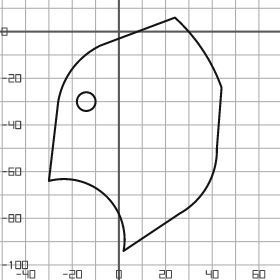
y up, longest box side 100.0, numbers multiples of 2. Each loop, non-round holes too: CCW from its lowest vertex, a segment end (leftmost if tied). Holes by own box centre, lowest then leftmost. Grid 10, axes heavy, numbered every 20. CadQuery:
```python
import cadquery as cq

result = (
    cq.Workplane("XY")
    .moveTo(2.0, -94.0)
    .lineTo(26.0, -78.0)
    .threePointArc((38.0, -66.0), (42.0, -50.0))
    .lineTo(44.0, -24.0)
    .threePointArc((36.0, -8.0), (24.0, 6.0))
    .lineTo(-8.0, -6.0)
    .threePointArc((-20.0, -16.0), (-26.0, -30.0))
    .lineTo(-30.0, -64.0)
    .threePointArc((-6.0, -70.0), (2.0, -94.0))
    .close()
    .moveTo(-14.0, -30.0)
    .circle(4.0)
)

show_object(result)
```